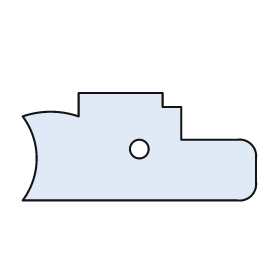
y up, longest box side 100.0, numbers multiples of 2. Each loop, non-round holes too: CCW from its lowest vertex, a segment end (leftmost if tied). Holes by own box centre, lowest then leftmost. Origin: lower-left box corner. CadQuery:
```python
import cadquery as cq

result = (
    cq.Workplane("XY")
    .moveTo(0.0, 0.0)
    .lineTo(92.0, 0.0)
    .threePointArc((98.0, 2.0), (100.0, 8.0))
    .lineTo(100.0, 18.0)
    .threePointArc((98.0, 24.0), (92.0, 26.0))
    .lineTo(68.0, 26.0)
    .lineTo(68.0, 40.0)
    .lineTo(60.0, 40.0)
    .lineTo(60.0, 46.0)
    .lineTo(24.0, 46.0)
    .lineTo(24.0, 36.0)
    .threePointArc((12.0, 38.0), (0.0, 36.0))
    .threePointArc((6.0, 18.0), (0.0, 0.0))
    .close()
    .moveTo(50.0, 22.0)
    .circle(4.0)
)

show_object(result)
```